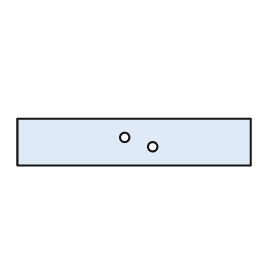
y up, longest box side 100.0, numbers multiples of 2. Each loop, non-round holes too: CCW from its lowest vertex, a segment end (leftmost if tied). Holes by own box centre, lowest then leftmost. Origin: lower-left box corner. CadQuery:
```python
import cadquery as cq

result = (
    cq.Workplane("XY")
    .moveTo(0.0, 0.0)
    .lineTo(100.0, 0.0)
    .lineTo(100.0, 20.0)
    .lineTo(0.0, 20.0)
    .close()
    .moveTo(58.0, 8.0)
    .circle(2.0)
    .moveTo(46.0, 12.0)
    .circle(2.0)
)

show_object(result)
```